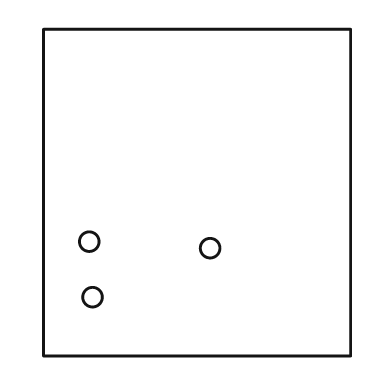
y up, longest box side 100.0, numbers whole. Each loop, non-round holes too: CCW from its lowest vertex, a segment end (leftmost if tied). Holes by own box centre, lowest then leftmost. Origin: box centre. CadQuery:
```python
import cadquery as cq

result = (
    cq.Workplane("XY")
    .moveTo(-47.0, -50.0)
    .lineTo(47.0, -50.0)
    .lineTo(47.0, 50.0)
    .lineTo(-47.0, 50.0)
    .close()
    .moveTo(-32.0, -32.0)
    .circle(3.0)
    .moveTo(4.0, -17.0)
    .circle(3.0)
    .moveTo(-33.0, -15.0)
    .circle(3.0)
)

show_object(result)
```